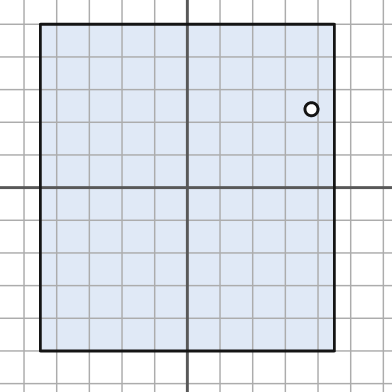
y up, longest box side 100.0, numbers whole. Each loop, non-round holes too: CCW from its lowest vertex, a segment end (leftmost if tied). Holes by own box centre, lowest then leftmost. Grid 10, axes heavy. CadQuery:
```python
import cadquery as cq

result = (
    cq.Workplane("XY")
    .moveTo(-45.0, -50.0)
    .lineTo(45.0, -50.0)
    .lineTo(45.0, 50.0)
    .lineTo(-45.0, 50.0)
    .close()
    .moveTo(38.0, 24.0)
    .circle(2.0)
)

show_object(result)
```